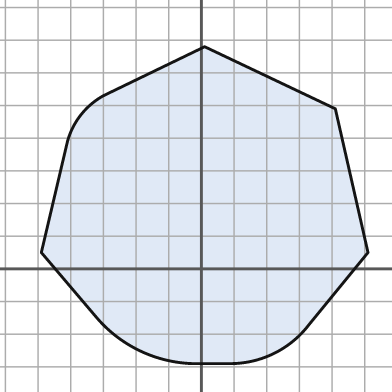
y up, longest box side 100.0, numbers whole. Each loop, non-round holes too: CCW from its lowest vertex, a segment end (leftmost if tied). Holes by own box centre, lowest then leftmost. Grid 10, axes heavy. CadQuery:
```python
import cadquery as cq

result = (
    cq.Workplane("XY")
    .moveTo(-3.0, -29.0)
    .lineTo(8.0, -29.0)
    .threePointArc((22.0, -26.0), (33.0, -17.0))
    .lineTo(51.0, 5.0)
    .lineTo(41.0, 49.0)
    .lineTo(1.0, 68.0)
    .lineTo(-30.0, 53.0)
    .threePointArc((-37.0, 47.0), (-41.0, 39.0))
    .lineTo(-49.0, 5.0)
    .lineTo(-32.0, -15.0)
    .threePointArc((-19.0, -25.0), (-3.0, -29.0))
    .close()
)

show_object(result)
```